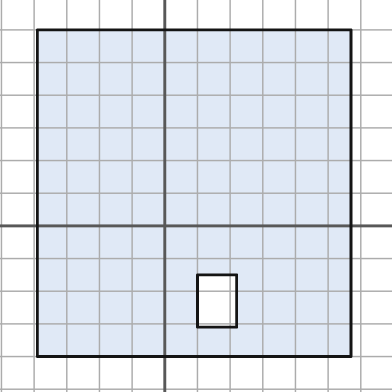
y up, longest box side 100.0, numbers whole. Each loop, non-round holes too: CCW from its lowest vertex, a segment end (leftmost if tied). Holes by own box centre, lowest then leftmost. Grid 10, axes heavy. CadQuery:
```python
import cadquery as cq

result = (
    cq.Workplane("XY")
    .moveTo(-39.0, -40.0)
    .lineTo(57.0, -40.0)
    .lineTo(57.0, 60.0)
    .lineTo(-39.0, 60.0)
    .close()
    .moveTo(10.0, -31.0)
    .lineTo(22.0, -31.0)
    .lineTo(22.0, -15.0)
    .lineTo(10.0, -15.0)
    .close()
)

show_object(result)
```